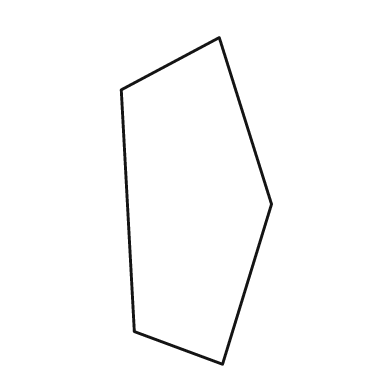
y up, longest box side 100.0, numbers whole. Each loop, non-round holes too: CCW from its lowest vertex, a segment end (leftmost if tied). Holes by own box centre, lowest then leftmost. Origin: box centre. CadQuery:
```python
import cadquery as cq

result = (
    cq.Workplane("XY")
    .moveTo(8.0, -50.0)
    .lineTo(23.0, -1.0)
    .lineTo(7.0, 50.0)
    .lineTo(-23.0, 34.0)
    .lineTo(-19.0, -40.0)
    .close()
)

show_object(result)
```